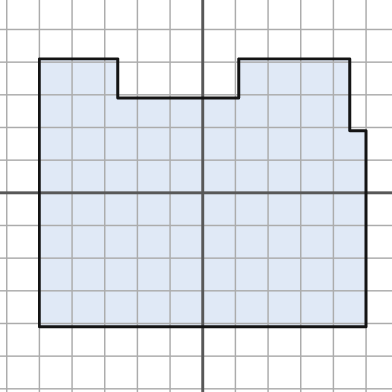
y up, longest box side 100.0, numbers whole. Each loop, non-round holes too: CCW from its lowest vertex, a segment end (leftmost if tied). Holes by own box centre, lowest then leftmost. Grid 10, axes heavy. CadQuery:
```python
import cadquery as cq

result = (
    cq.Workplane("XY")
    .moveTo(-50.0, -41.0)
    .lineTo(50.0, -41.0)
    .lineTo(50.0, 19.0)
    .lineTo(45.0, 19.0)
    .lineTo(45.0, 41.0)
    .lineTo(11.0, 41.0)
    .lineTo(11.0, 29.0)
    .lineTo(-26.0, 29.0)
    .lineTo(-26.0, 41.0)
    .lineTo(-50.0, 41.0)
    .close()
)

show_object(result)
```